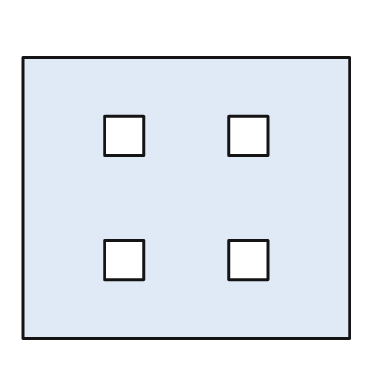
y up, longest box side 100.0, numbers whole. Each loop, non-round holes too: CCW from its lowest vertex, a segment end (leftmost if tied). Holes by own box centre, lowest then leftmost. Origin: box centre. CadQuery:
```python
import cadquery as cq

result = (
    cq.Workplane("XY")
    .moveTo(-50.0, -43.0)
    .lineTo(50.0, -43.0)
    .lineTo(50.0, 43.0)
    .lineTo(-50.0, 43.0)
    .close()
    .moveTo(-25.0, -25.0)
    .lineTo(-13.0, -25.0)
    .lineTo(-13.0, -13.0)
    .lineTo(-25.0, -13.0)
    .close()
    .moveTo(13.0, -25.0)
    .lineTo(25.0, -25.0)
    .lineTo(25.0, -13.0)
    .lineTo(13.0, -13.0)
    .close()
    .moveTo(-25.0, 13.0)
    .lineTo(-13.0, 13.0)
    .lineTo(-13.0, 25.0)
    .lineTo(-25.0, 25.0)
    .close()
    .moveTo(13.0, 13.0)
    .lineTo(25.0, 13.0)
    .lineTo(25.0, 25.0)
    .lineTo(13.0, 25.0)
    .close()
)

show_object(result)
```